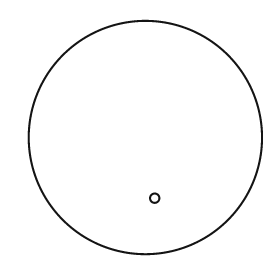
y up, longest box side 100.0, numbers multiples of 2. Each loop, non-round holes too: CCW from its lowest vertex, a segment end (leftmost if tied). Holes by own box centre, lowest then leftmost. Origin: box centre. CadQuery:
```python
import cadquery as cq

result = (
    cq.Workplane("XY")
    .moveTo(0.0, 0.0)
    .circle(50.0)
    .moveTo(4.0, -26.0)
    .circle(2.0)
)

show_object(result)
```